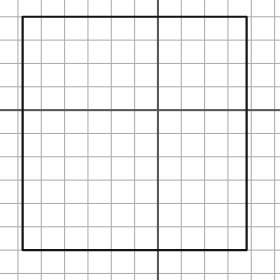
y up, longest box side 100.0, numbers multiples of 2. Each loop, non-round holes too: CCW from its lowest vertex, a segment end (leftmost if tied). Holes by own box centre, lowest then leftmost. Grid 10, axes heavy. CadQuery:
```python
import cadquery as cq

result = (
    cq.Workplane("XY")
    .moveTo(-58.0, -60.0)
    .lineTo(38.0, -60.0)
    .lineTo(38.0, 40.0)
    .lineTo(-58.0, 40.0)
    .close()
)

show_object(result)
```